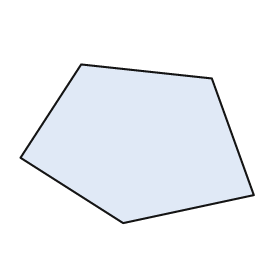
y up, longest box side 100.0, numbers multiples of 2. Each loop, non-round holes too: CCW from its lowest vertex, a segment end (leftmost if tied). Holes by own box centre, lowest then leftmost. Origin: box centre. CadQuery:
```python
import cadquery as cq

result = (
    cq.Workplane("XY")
    .moveTo(-6.0, -34.0)
    .lineTo(50.0, -22.0)
    .lineTo(32.0, 28.0)
    .lineTo(-24.0, 34.0)
    .lineTo(-50.0, -6.0)
    .close()
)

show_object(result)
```